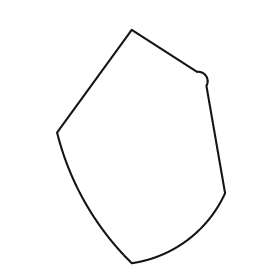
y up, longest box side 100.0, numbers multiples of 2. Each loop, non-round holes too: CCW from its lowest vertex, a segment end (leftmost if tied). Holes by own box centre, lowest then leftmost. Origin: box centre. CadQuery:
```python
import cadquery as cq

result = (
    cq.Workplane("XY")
    .moveTo(-4.0, -50.0)
    .threePointArc((20.0, -40.0), (36.0, -20.0))
    .lineTo(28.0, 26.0)
    .threePointArc((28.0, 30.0), (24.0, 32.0))
    .lineTo(-4.0, 50.0)
    .lineTo(-36.0, 6.0)
    .threePointArc((-24.0, -24.0), (-4.0, -50.0))
    .close()
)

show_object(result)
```